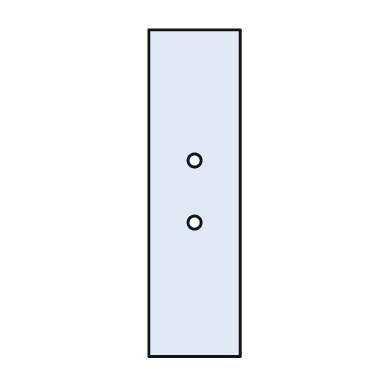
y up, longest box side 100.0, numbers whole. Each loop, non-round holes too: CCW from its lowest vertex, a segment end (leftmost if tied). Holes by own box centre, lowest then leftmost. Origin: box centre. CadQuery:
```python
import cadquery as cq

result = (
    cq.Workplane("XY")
    .moveTo(-14.0, -50.0)
    .lineTo(14.0, -50.0)
    .lineTo(14.0, 50.0)
    .lineTo(-14.0, 50.0)
    .close()
    .moveTo(0.0, -9.0)
    .circle(2.0)
    .moveTo(0.0, 10.0)
    .circle(2.0)
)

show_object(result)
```